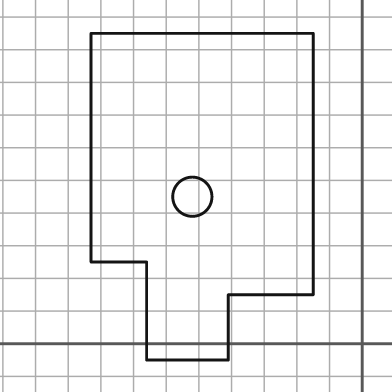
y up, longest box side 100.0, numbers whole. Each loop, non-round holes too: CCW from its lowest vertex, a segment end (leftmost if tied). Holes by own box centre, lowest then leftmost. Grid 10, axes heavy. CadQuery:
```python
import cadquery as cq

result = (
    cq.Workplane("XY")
    .moveTo(-66.0, -5.0)
    .lineTo(-41.0, -5.0)
    .lineTo(-41.0, 15.0)
    .lineTo(-15.0, 15.0)
    .lineTo(-15.0, 95.0)
    .lineTo(-83.0, 95.0)
    .lineTo(-83.0, 25.0)
    .lineTo(-66.0, 25.0)
    .close()
    .moveTo(-52.0, 45.0)
    .circle(6.0)
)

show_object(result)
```